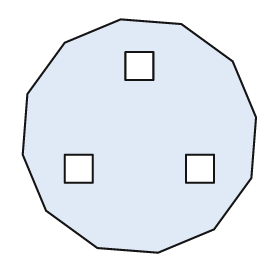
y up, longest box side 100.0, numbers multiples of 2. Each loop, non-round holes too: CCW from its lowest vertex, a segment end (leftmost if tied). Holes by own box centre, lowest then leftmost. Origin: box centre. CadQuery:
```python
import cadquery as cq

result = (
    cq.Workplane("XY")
    .moveTo(8.0, -50.0)
    .lineTo(32.0, -40.0)
    .lineTo(48.0, -18.0)
    .lineTo(50.0, 8.0)
    .lineTo(40.0, 32.0)
    .lineTo(18.0, 48.0)
    .lineTo(-8.0, 50.0)
    .lineTo(-32.0, 40.0)
    .lineTo(-48.0, 18.0)
    .lineTo(-50.0, -8.0)
    .lineTo(-40.0, -32.0)
    .lineTo(-18.0, -48.0)
    .close()
    .moveTo(-32.0, -20.0)
    .lineTo(-20.0, -20.0)
    .lineTo(-20.0, -8.0)
    .lineTo(-32.0, -8.0)
    .close()
    .moveTo(20.0, -20.0)
    .lineTo(32.0, -20.0)
    .lineTo(32.0, -8.0)
    .lineTo(20.0, -8.0)
    .close()
    .moveTo(-6.0, 24.0)
    .lineTo(6.0, 24.0)
    .lineTo(6.0, 36.0)
    .lineTo(-6.0, 36.0)
    .close()
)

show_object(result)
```